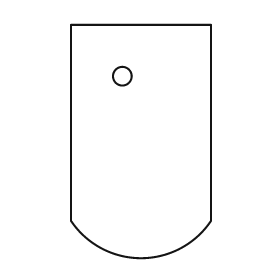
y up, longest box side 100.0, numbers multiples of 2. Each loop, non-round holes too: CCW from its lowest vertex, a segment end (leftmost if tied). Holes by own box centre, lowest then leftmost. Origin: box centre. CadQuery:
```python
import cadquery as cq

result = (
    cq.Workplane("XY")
    .moveTo(-30.0, -34.0)
    .threePointArc((0.0, -50.0), (30.0, -34.0))
    .lineTo(30.0, 50.0)
    .lineTo(-30.0, 50.0)
    .close()
    .moveTo(-8.0, 28.0)
    .circle(4.0)
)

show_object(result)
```